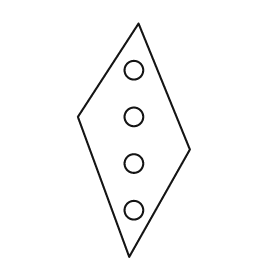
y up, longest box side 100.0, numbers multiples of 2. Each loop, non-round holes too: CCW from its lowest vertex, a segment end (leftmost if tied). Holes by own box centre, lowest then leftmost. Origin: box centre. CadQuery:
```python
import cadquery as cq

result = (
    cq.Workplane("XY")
    .moveTo(-2.0, -50.0)
    .lineTo(24.0, -4.0)
    .lineTo(2.0, 50.0)
    .lineTo(-24.0, 10.0)
    .close()
    .moveTo(0.0, -30.0)
    .circle(4.0)
    .moveTo(0.0, -10.0)
    .circle(4.0)
    .moveTo(0.0, 10.0)
    .circle(4.0)
    .moveTo(0.0, 30.0)
    .circle(4.0)
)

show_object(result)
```